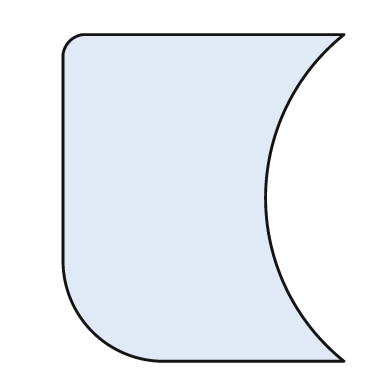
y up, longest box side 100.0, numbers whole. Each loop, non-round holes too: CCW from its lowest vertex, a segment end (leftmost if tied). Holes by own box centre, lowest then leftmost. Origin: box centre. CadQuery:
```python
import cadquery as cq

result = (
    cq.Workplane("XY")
    .moveTo(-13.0, -50.0)
    .lineTo(43.0, -50.0)
    .threePointArc((19.0, 0.0), (43.0, 50.0))
    .lineTo(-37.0, 50.0)
    .threePointArc((-41.0, 48.0), (-43.0, 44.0))
    .lineTo(-43.0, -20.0)
    .threePointArc((-34.0, -41.0), (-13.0, -50.0))
    .close()
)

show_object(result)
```